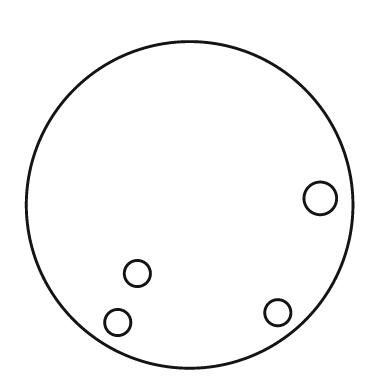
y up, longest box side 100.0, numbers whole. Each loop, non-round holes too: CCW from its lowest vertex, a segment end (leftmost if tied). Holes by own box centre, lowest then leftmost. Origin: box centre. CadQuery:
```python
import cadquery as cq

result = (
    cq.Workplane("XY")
    .moveTo(0.0, 0.0)
    .circle(50.0)
    .moveTo(-22.0, -36.0)
    .circle(4.0)
    .moveTo(27.0, -33.0)
    .circle(4.0)
    .moveTo(-16.0, -21.0)
    .circle(4.0)
    .moveTo(40.0, 2.0)
    .circle(5.0)
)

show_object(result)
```